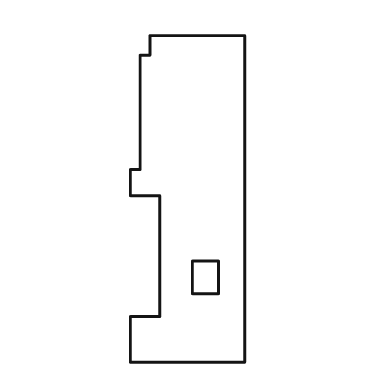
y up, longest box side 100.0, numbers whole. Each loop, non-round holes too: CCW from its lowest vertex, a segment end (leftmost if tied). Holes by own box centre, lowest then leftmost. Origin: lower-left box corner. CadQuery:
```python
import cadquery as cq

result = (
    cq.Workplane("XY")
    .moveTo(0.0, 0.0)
    .lineTo(35.0, 0.0)
    .lineTo(35.0, 100.0)
    .lineTo(6.0, 100.0)
    .lineTo(6.0, 94.0)
    .lineTo(3.0, 94.0)
    .lineTo(3.0, 59.0)
    .lineTo(0.0, 59.0)
    .lineTo(0.0, 51.0)
    .lineTo(9.0, 51.0)
    .lineTo(9.0, 14.0)
    .lineTo(0.0, 14.0)
    .close()
    .moveTo(19.0, 21.0)
    .lineTo(27.0, 21.0)
    .lineTo(27.0, 31.0)
    .lineTo(19.0, 31.0)
    .close()
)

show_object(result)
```